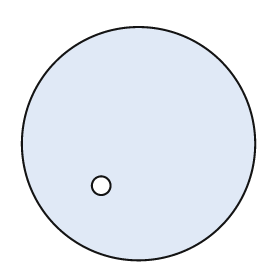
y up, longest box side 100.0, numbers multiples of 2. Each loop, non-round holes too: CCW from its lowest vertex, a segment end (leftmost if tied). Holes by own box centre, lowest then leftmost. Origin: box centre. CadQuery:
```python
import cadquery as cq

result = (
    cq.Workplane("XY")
    .moveTo(0.0, 0.0)
    .circle(50.0)
    .moveTo(-16.0, -18.0)
    .circle(4.0)
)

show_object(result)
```